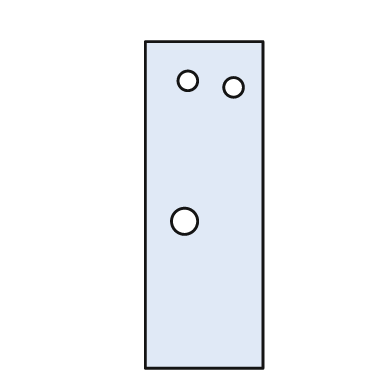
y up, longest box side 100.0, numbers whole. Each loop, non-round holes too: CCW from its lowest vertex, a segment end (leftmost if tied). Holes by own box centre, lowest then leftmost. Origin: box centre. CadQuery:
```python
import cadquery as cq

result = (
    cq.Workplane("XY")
    .moveTo(-18.0, -50.0)
    .lineTo(18.0, -50.0)
    .lineTo(18.0, 50.0)
    .lineTo(-18.0, 50.0)
    .close()
    .moveTo(-6.0, -5.0)
    .circle(4.0)
    .moveTo(9.0, 36.0)
    .circle(3.0)
    .moveTo(-5.0, 38.0)
    .circle(3.0)
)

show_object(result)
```